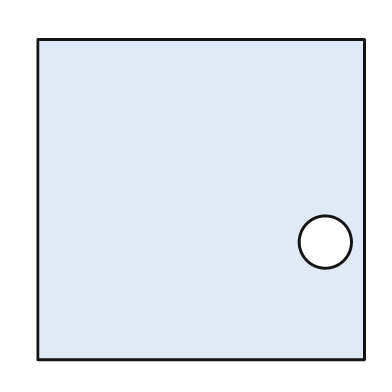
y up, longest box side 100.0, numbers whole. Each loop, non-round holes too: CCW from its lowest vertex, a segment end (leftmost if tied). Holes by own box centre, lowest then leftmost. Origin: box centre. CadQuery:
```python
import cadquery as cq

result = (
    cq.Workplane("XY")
    .moveTo(-50.0, -49.0)
    .lineTo(50.0, -49.0)
    .lineTo(50.0, 49.0)
    .lineTo(-50.0, 49.0)
    .close()
    .moveTo(38.0, -13.0)
    .circle(8.0)
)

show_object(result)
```